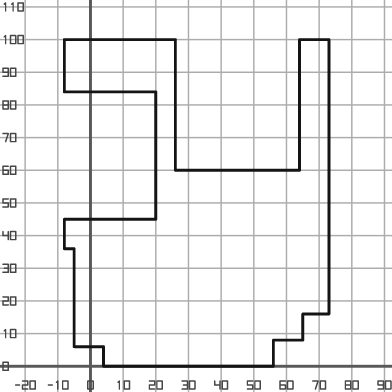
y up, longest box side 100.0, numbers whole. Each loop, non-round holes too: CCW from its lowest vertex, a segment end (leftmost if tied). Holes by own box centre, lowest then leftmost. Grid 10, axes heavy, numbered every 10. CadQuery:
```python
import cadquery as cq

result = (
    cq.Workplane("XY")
    .moveTo(4.0, 0.0)
    .lineTo(56.0, 0.0)
    .lineTo(56.0, 8.0)
    .lineTo(65.0, 8.0)
    .lineTo(65.0, 16.0)
    .lineTo(73.0, 16.0)
    .lineTo(73.0, 100.0)
    .lineTo(64.0, 100.0)
    .lineTo(64.0, 60.0)
    .lineTo(26.0, 60.0)
    .lineTo(26.0, 100.0)
    .lineTo(-8.0, 100.0)
    .lineTo(-8.0, 84.0)
    .lineTo(20.0, 84.0)
    .lineTo(20.0, 45.0)
    .lineTo(-8.0, 45.0)
    .lineTo(-8.0, 36.0)
    .lineTo(-5.0, 36.0)
    .lineTo(-5.0, 6.0)
    .lineTo(4.0, 6.0)
    .close()
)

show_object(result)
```